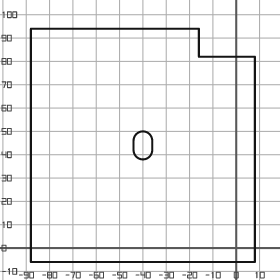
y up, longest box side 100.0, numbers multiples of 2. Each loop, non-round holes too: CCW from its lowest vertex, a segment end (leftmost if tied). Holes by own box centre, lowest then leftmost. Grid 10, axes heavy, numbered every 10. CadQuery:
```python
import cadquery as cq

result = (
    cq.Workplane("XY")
    .moveTo(-88.0, -6.0)
    .lineTo(8.0, -6.0)
    .lineTo(8.0, 82.0)
    .lineTo(-16.0, 82.0)
    .lineTo(-16.0, 94.0)
    .lineTo(-88.0, 94.0)
    .close()
    .moveTo(-44.0, 42.0)
    .threePointArc((-40.0, 38.0), (-36.0, 42.0))
    .lineTo(-36.0, 46.0)
    .threePointArc((-40.0, 50.0), (-44.0, 46.0))
    .close()
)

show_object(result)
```